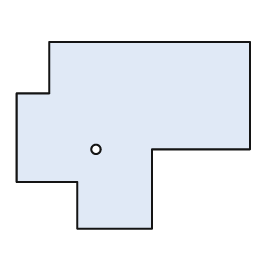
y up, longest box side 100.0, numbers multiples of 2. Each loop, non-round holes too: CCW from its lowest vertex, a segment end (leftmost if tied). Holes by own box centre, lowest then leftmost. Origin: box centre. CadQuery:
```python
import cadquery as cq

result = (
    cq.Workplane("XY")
    .moveTo(-24.0, -40.0)
    .lineTo(8.0, -40.0)
    .lineTo(8.0, -6.0)
    .lineTo(50.0, -6.0)
    .lineTo(50.0, 40.0)
    .lineTo(-36.0, 40.0)
    .lineTo(-36.0, 18.0)
    .lineTo(-50.0, 18.0)
    .lineTo(-50.0, -20.0)
    .lineTo(-24.0, -20.0)
    .close()
    .moveTo(-16.0, -6.0)
    .circle(2.0)
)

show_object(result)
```